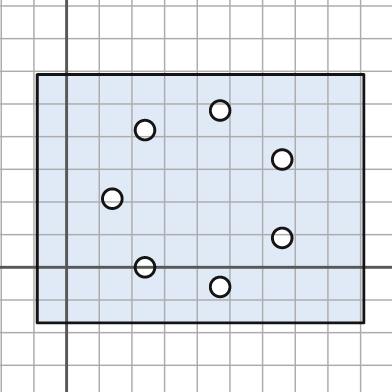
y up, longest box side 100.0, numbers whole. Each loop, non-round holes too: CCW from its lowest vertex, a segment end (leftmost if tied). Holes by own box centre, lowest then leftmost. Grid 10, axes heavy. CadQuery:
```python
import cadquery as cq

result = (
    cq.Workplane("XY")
    .moveTo(-9.0, -17.0)
    .lineTo(91.0, -17.0)
    .lineTo(91.0, 59.0)
    .lineTo(-9.0, 59.0)
    .close()
    .moveTo(47.0, -6.0)
    .circle(3.0)
    .moveTo(24.0, 0.0)
    .circle(3.0)
    .moveTo(66.0, 9.0)
    .circle(3.0)
    .moveTo(14.0, 21.0)
    .circle(3.0)
    .moveTo(66.0, 33.0)
    .circle(3.0)
    .moveTo(24.0, 42.0)
    .circle(3.0)
    .moveTo(47.0, 48.0)
    .circle(3.0)
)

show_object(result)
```